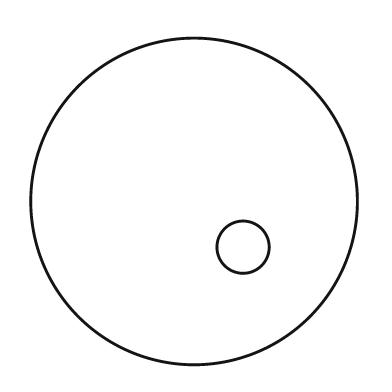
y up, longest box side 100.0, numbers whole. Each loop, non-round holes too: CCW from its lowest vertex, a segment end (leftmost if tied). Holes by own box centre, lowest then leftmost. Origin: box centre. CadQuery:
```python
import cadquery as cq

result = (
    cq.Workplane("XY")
    .moveTo(0.0, 0.0)
    .circle(50.0)
    .moveTo(15.0, -14.0)
    .circle(8.0)
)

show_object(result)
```